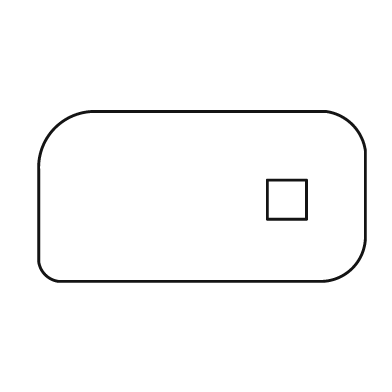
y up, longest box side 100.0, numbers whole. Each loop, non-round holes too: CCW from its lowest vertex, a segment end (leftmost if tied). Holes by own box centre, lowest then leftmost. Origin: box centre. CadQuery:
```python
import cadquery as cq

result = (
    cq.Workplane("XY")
    .moveTo(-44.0, -26.0)
    .lineTo(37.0, -26.0)
    .threePointArc((46.0, -22.0), (50.0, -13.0))
    .lineTo(50.0, 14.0)
    .threePointArc((46.0, 22.0), (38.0, 26.0))
    .lineTo(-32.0, 26.0)
    .threePointArc((-45.0, 21.0), (-50.0, 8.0))
    .lineTo(-50.0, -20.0)
    .threePointArc((-48.0, -24.0), (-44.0, -26.0))
    .close()
    .moveTo(20.0, -7.0)
    .lineTo(32.0, -7.0)
    .lineTo(32.0, 5.0)
    .lineTo(20.0, 5.0)
    .close()
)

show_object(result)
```